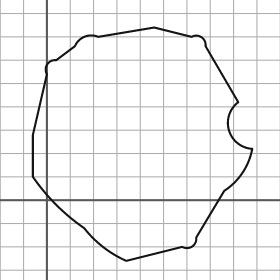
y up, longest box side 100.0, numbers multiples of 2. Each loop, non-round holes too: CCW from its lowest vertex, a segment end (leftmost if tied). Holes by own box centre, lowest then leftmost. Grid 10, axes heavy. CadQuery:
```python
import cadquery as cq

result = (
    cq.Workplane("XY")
    .moveTo(34.0, -26.0)
    .lineTo(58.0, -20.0)
    .threePointArc((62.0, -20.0), (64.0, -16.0))
    .lineTo(76.0, 4.0)
    .threePointArc((84.0, 12.0), (88.0, 22.0))
    .threePointArc((78.0, 30.0), (82.0, 42.0))
    .lineTo(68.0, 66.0)
    .threePointArc((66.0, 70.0), (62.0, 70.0))
    .lineTo(46.0, 74.0)
    .lineTo(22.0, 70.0)
    .threePointArc((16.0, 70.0), (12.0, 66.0))
    .lineTo(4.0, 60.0)
    .threePointArc((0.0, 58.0), (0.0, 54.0))
    .lineTo(-6.0, 28.0)
    .lineTo(-6.0, 10.0)
    .threePointArc((4.0, -2.0), (16.0, -12.0))
    .threePointArc((24.0, -20.0), (34.0, -26.0))
    .close()
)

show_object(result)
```